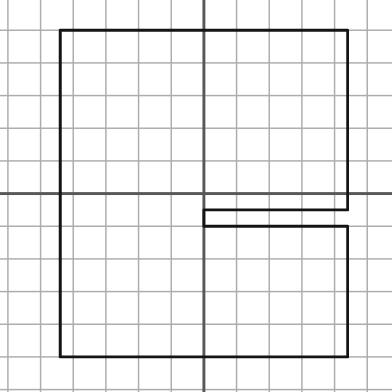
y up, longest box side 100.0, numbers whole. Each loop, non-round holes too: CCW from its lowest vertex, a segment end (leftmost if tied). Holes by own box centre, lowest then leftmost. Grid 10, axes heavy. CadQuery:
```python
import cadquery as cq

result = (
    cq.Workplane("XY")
    .moveTo(-44.0, -50.0)
    .lineTo(44.0, -50.0)
    .lineTo(44.0, -10.0)
    .lineTo(0.0, -10.0)
    .lineTo(0.0, -5.0)
    .lineTo(44.0, -5.0)
    .lineTo(44.0, 50.0)
    .lineTo(-44.0, 50.0)
    .close()
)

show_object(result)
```